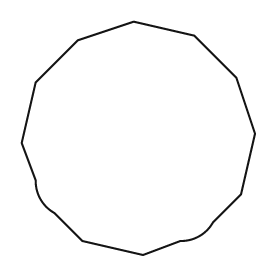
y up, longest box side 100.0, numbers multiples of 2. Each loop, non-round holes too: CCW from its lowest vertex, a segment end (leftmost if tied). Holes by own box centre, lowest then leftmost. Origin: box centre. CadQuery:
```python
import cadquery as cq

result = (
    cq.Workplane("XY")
    .moveTo(2.0, -50.0)
    .lineTo(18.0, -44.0)
    .threePointArc((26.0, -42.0), (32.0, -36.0))
    .lineTo(44.0, -24.0)
    .lineTo(50.0, 2.0)
    .lineTo(42.0, 26.0)
    .lineTo(24.0, 44.0)
    .lineTo(-2.0, 50.0)
    .lineTo(-26.0, 42.0)
    .lineTo(-44.0, 24.0)
    .lineTo(-50.0, -2.0)
    .lineTo(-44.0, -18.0)
    .threePointArc((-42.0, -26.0), (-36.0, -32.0))
    .lineTo(-24.0, -44.0)
    .close()
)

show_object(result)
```